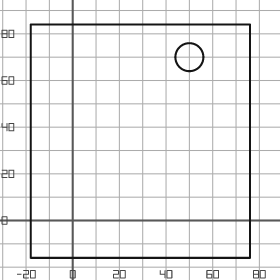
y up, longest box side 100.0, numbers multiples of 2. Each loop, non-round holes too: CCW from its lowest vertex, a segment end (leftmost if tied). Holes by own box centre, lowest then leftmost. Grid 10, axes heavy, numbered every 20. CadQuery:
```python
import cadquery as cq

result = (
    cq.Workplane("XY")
    .moveTo(-18.0, -16.0)
    .lineTo(76.0, -16.0)
    .lineTo(76.0, 84.0)
    .lineTo(-18.0, 84.0)
    .close()
    .moveTo(50.0, 70.0)
    .circle(6.0)
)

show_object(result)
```